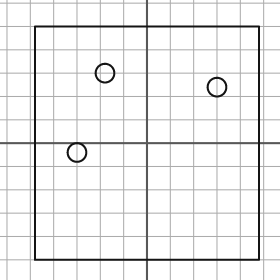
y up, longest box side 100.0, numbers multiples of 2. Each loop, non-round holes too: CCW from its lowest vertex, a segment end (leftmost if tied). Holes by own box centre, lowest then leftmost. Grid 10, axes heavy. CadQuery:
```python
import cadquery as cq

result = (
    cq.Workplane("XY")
    .moveTo(-48.0, -50.0)
    .lineTo(48.0, -50.0)
    .lineTo(48.0, 50.0)
    .lineTo(-48.0, 50.0)
    .close()
    .moveTo(-30.0, -4.0)
    .circle(4.0)
    .moveTo(30.0, 24.0)
    .circle(4.0)
    .moveTo(-18.0, 30.0)
    .circle(4.0)
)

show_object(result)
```